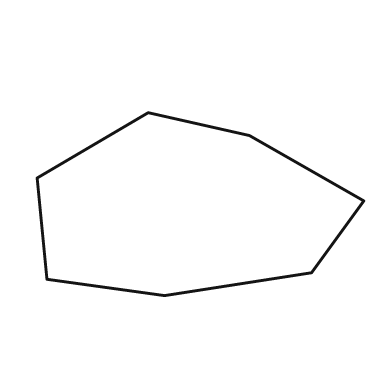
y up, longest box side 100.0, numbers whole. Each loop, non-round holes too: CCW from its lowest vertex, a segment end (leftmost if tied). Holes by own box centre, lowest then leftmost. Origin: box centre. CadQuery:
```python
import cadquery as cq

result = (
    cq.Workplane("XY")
    .moveTo(-11.0, -28.0)
    .lineTo(34.0, -21.0)
    .lineTo(50.0, 1.0)
    .lineTo(15.0, 21.0)
    .lineTo(-16.0, 28.0)
    .lineTo(-50.0, 8.0)
    .lineTo(-47.0, -23.0)
    .close()
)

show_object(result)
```